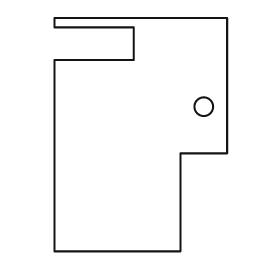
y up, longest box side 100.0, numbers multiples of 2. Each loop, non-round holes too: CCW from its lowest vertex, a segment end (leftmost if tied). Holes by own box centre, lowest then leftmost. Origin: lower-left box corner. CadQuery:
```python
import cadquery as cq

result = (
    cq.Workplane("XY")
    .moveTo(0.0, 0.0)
    .lineTo(54.0, 0.0)
    .lineTo(54.0, 42.0)
    .lineTo(74.0, 42.0)
    .lineTo(74.0, 100.0)
    .lineTo(0.0, 100.0)
    .lineTo(0.0, 96.0)
    .lineTo(34.0, 96.0)
    .lineTo(34.0, 82.0)
    .lineTo(0.0, 82.0)
    .close()
    .moveTo(64.0, 62.0)
    .circle(4.0)
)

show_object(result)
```